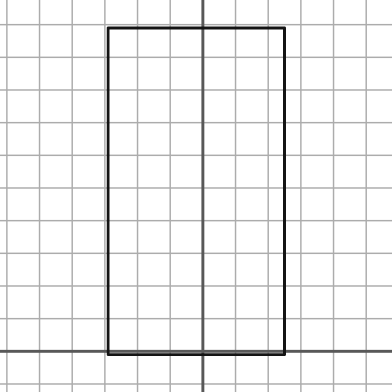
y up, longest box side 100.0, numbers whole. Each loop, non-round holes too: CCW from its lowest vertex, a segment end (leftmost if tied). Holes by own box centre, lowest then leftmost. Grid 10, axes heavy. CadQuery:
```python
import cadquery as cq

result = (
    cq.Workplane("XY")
    .moveTo(-29.0, -1.0)
    .lineTo(25.0, -1.0)
    .lineTo(25.0, 99.0)
    .lineTo(-29.0, 99.0)
    .close()
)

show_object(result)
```